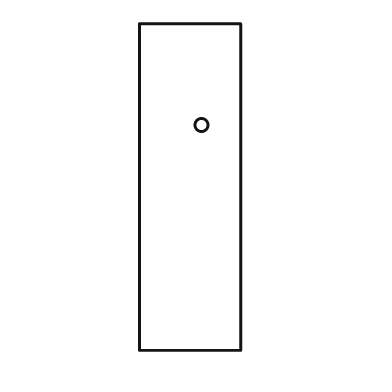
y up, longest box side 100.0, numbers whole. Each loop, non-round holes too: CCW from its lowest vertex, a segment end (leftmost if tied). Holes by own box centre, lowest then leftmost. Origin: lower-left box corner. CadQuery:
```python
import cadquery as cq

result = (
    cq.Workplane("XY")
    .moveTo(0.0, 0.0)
    .lineTo(31.0, 0.0)
    .lineTo(31.0, 100.0)
    .lineTo(0.0, 100.0)
    .close()
    .moveTo(19.0, 69.0)
    .circle(2.0)
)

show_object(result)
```